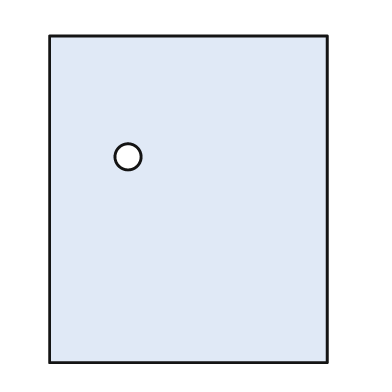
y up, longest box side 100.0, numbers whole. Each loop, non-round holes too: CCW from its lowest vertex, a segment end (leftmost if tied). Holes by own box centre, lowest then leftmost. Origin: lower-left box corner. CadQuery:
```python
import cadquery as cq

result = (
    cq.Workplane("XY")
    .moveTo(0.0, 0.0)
    .lineTo(85.0, 0.0)
    .lineTo(85.0, 100.0)
    .lineTo(0.0, 100.0)
    .close()
    .moveTo(24.0, 63.0)
    .circle(4.0)
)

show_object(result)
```